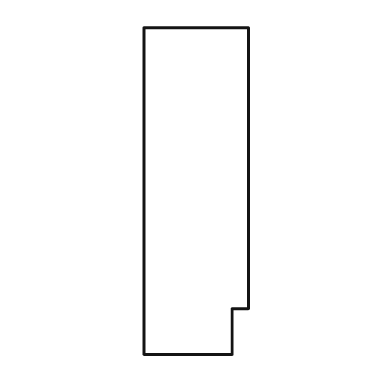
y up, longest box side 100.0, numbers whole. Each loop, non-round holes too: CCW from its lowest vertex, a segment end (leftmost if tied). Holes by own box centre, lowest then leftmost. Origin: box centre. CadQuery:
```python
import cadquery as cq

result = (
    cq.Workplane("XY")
    .moveTo(-16.0, -50.0)
    .lineTo(11.0, -50.0)
    .lineTo(11.0, -36.0)
    .lineTo(16.0, -36.0)
    .lineTo(16.0, 50.0)
    .lineTo(-16.0, 50.0)
    .close()
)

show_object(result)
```